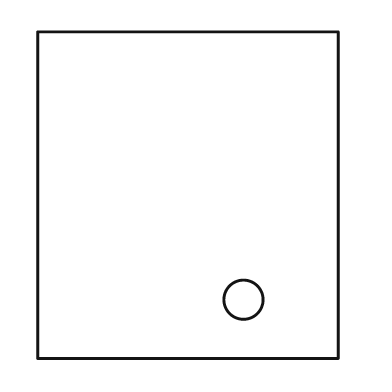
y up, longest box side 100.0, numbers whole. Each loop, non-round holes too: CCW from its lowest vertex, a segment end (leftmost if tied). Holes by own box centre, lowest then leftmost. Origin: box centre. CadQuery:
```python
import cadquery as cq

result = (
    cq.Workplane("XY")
    .moveTo(-46.0, -50.0)
    .lineTo(46.0, -50.0)
    .lineTo(46.0, 50.0)
    .lineTo(-46.0, 50.0)
    .close()
    .moveTo(17.0, -32.0)
    .circle(6.0)
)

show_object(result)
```